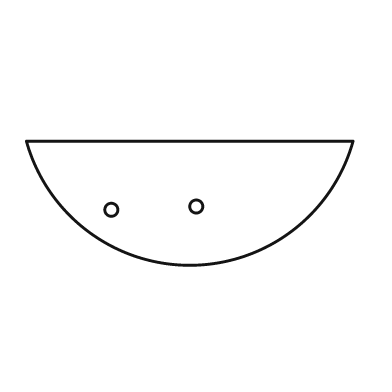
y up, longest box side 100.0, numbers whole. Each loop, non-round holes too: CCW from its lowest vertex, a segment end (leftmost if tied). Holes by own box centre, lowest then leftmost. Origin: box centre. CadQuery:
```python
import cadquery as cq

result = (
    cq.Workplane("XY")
    .moveTo(-50.0, 19.0)
    .threePointArc((0.0, -19.0), (50.0, 19.0))
    .close()
    .moveTo(-24.0, -2.0)
    .circle(2.0)
    .moveTo(2.0, -1.0)
    .circle(2.0)
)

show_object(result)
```